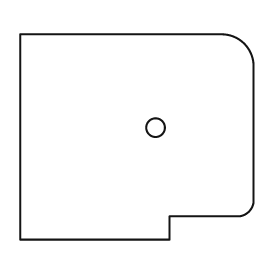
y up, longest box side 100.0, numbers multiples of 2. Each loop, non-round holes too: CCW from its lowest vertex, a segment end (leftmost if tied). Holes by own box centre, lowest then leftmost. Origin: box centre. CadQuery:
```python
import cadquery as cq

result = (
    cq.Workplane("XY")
    .moveTo(-50.0, -44.0)
    .lineTo(14.0, -44.0)
    .lineTo(14.0, -34.0)
    .lineTo(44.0, -34.0)
    .threePointArc((48.0, -32.0), (50.0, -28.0))
    .lineTo(50.0, 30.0)
    .threePointArc((46.0, 40.0), (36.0, 44.0))
    .lineTo(-50.0, 44.0)
    .close()
    .moveTo(8.0, 4.0)
    .circle(4.0)
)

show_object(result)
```